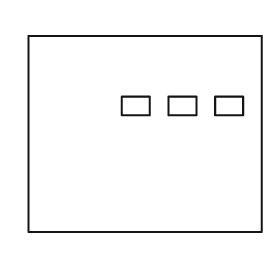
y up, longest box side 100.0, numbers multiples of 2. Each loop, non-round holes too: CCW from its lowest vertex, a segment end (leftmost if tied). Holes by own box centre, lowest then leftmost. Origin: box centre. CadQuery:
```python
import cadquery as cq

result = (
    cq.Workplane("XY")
    .moveTo(-50.0, -42.0)
    .lineTo(50.0, -42.0)
    .lineTo(50.0, 42.0)
    .lineTo(-50.0, 42.0)
    .close()
    .moveTo(-10.0, 8.0)
    .lineTo(2.0, 8.0)
    .lineTo(2.0, 16.0)
    .lineTo(-10.0, 16.0)
    .close()
    .moveTo(10.0, 8.0)
    .lineTo(22.0, 8.0)
    .lineTo(22.0, 16.0)
    .lineTo(10.0, 16.0)
    .close()
    .moveTo(30.0, 8.0)
    .lineTo(42.0, 8.0)
    .lineTo(42.0, 16.0)
    .lineTo(30.0, 16.0)
    .close()
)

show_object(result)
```